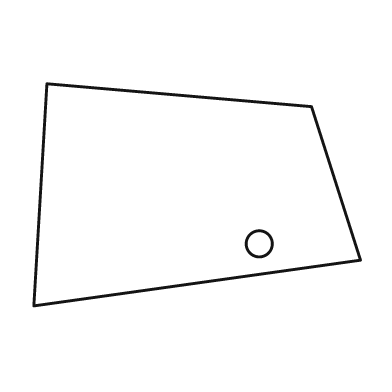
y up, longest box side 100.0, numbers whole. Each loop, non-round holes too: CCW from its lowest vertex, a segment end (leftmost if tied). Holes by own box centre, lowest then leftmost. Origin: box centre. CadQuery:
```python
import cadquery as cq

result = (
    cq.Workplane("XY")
    .moveTo(-50.0, -34.0)
    .lineTo(50.0, -20.0)
    .lineTo(35.0, 27.0)
    .lineTo(-46.0, 34.0)
    .close()
    .moveTo(19.0, -15.0)
    .circle(4.0)
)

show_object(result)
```